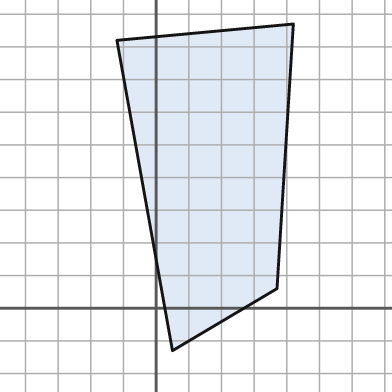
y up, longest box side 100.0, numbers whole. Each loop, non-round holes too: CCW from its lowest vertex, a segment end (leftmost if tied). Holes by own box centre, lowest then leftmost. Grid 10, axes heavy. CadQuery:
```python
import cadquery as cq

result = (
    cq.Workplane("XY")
    .moveTo(5.0, -13.0)
    .lineTo(37.0, 6.0)
    .lineTo(42.0, 87.0)
    .lineTo(-12.0, 82.0)
    .close()
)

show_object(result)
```